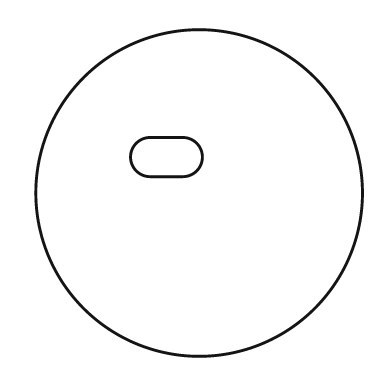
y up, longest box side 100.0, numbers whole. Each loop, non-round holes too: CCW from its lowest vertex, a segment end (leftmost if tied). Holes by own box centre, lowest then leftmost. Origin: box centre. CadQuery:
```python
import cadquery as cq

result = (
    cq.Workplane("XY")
    .moveTo(0.0, 0.0)
    .circle(50.0)
    .moveTo(-15.0, 5.0)
    .lineTo(-5.0, 5.0)
    .threePointArc((1.0, 11.0), (-5.0, 17.0))
    .lineTo(-15.0, 17.0)
    .threePointArc((-21.0, 11.0), (-15.0, 5.0))
    .close()
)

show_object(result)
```